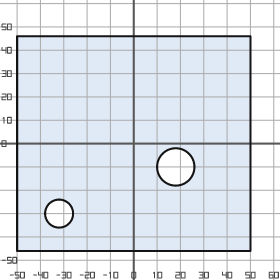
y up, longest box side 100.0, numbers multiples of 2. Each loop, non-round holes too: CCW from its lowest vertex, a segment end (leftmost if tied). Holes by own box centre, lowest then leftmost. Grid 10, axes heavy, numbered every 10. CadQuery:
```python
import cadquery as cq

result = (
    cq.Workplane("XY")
    .moveTo(-50.0, -46.0)
    .lineTo(50.0, -46.0)
    .lineTo(50.0, 46.0)
    .lineTo(-50.0, 46.0)
    .close()
    .moveTo(-32.0, -30.0)
    .circle(6.0)
    .moveTo(18.0, -10.0)
    .circle(8.0)
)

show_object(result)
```